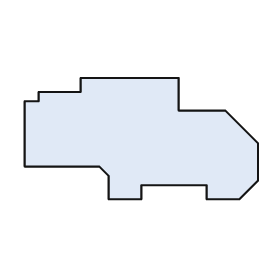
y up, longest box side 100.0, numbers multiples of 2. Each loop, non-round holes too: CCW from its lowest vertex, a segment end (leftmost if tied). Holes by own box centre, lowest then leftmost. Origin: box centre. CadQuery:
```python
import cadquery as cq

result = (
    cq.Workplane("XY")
    .moveTo(-14.0, -26.0)
    .lineTo(0.0, -26.0)
    .lineTo(0.0, -20.0)
    .lineTo(28.0, -20.0)
    .lineTo(28.0, -26.0)
    .lineTo(42.0, -26.0)
    .lineTo(50.0, -18.0)
    .lineTo(50.0, -2.0)
    .lineTo(36.0, 12.0)
    .lineTo(16.0, 12.0)
    .lineTo(16.0, 26.0)
    .lineTo(-26.0, 26.0)
    .lineTo(-26.0, 20.0)
    .lineTo(-44.0, 20.0)
    .lineTo(-44.0, 16.0)
    .lineTo(-50.0, 16.0)
    .lineTo(-50.0, -12.0)
    .lineTo(-18.0, -12.0)
    .lineTo(-14.0, -16.0)
    .close()
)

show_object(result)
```